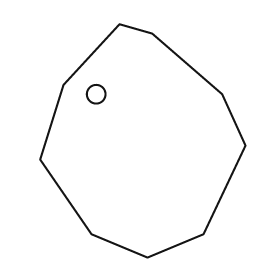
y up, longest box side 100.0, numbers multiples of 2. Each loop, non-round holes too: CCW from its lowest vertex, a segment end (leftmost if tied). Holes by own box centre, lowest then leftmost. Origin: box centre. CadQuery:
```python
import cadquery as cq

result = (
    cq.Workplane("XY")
    .moveTo(2.0, -50.0)
    .lineTo(26.0, -40.0)
    .lineTo(44.0, -2.0)
    .lineTo(34.0, 20.0)
    .lineTo(4.0, 46.0)
    .lineTo(-10.0, 50.0)
    .lineTo(-34.0, 24.0)
    .lineTo(-44.0, -8.0)
    .lineTo(-22.0, -40.0)
    .close()
    .moveTo(-20.0, 20.0)
    .circle(4.0)
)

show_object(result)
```